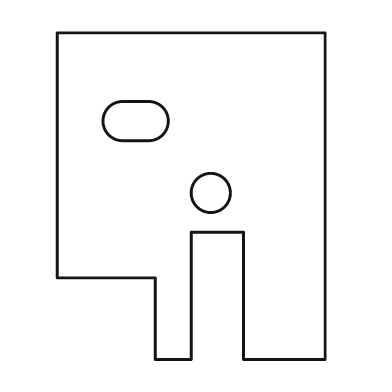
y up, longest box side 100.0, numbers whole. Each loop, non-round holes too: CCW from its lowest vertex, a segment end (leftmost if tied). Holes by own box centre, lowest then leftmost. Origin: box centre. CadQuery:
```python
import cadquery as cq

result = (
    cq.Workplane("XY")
    .moveTo(-11.0, -50.0)
    .lineTo(0.0, -50.0)
    .lineTo(0.0, -11.0)
    .lineTo(16.0, -11.0)
    .lineTo(16.0, -50.0)
    .lineTo(41.0, -50.0)
    .lineTo(41.0, 50.0)
    .lineTo(-41.0, 50.0)
    .lineTo(-41.0, -25.0)
    .lineTo(-11.0, -25.0)
    .close()
    .moveTo(6.0, 1.0)
    .circle(6.0)
    .moveTo(-21.0, 17.0)
    .lineTo(-13.0, 17.0)
    .threePointArc((-7.0, 23.0), (-13.0, 29.0))
    .lineTo(-21.0, 29.0)
    .threePointArc((-27.0, 23.0), (-21.0, 17.0))
    .close()
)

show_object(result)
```